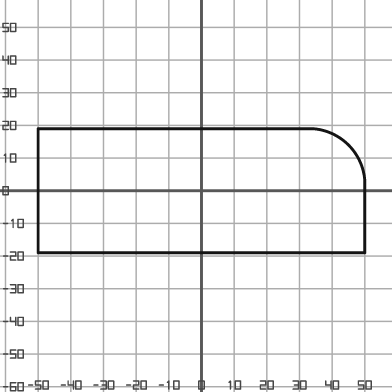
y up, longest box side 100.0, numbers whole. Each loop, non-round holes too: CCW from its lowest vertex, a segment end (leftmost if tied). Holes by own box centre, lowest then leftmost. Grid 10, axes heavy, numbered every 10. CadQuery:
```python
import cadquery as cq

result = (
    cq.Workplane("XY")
    .moveTo(-50.0, -19.0)
    .lineTo(50.0, -19.0)
    .lineTo(50.0, 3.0)
    .threePointArc((45.0, 14.0), (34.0, 19.0))
    .lineTo(-50.0, 19.0)
    .close()
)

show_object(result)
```